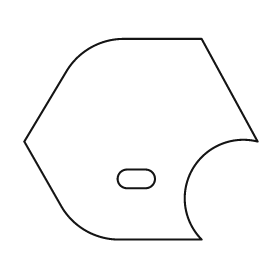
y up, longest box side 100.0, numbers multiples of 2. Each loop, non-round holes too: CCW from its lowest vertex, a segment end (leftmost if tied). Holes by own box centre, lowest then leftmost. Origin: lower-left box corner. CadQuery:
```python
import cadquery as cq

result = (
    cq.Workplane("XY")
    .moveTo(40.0, 0.0)
    .lineTo(76.0, 0.0)
    .threePointArc((72.0, 30.0), (100.0, 42.0))
    .lineTo(76.0, 86.0)
    .lineTo(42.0, 86.0)
    .threePointArc((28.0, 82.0), (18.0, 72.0))
    .lineTo(0.0, 42.0)
    .lineTo(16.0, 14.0)
    .threePointArc((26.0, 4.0), (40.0, 0.0))
    .close()
    .moveTo(44.0, 22.0)
    .lineTo(52.0, 22.0)
    .threePointArc((56.0, 26.0), (52.0, 30.0))
    .lineTo(44.0, 30.0)
    .threePointArc((40.0, 26.0), (44.0, 22.0))
    .close()
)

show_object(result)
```